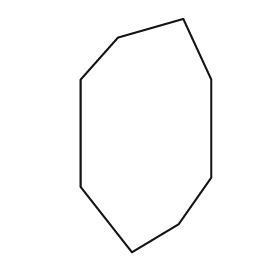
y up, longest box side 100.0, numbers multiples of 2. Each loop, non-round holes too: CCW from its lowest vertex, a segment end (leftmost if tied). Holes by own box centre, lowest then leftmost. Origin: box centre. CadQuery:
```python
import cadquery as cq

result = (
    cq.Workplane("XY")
    .moveTo(-6.0, -50.0)
    .lineTo(14.0, -38.0)
    .lineTo(28.0, -18.0)
    .lineTo(28.0, 24.0)
    .lineTo(16.0, 50.0)
    .lineTo(-12.0, 42.0)
    .lineTo(-28.0, 24.0)
    .lineTo(-28.0, -22.0)
    .close()
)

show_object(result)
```